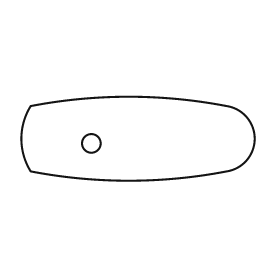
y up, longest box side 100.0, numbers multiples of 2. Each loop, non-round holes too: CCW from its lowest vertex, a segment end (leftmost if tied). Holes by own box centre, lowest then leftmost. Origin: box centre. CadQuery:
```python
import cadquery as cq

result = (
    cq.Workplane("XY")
    .moveTo(-46.0, -14.0)
    .threePointArc((-4.0, -18.0), (38.0, -14.0))
    .threePointArc((50.0, 0.0), (38.0, 14.0))
    .threePointArc((-4.0, 18.0), (-46.0, 14.0))
    .threePointArc((-50.0, 0.0), (-46.0, -14.0))
    .close()
    .moveTo(-20.0, -2.0)
    .circle(4.0)
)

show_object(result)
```